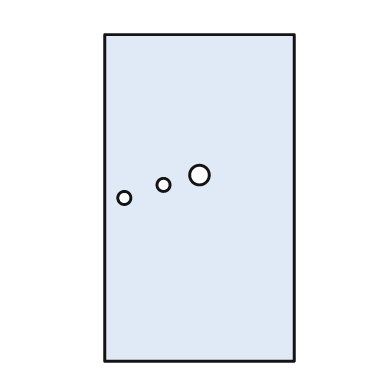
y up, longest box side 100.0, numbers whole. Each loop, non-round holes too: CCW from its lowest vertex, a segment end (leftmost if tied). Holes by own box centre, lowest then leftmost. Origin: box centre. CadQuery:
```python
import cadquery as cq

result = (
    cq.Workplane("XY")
    .moveTo(-29.0, -50.0)
    .lineTo(29.0, -50.0)
    .lineTo(29.0, 50.0)
    .lineTo(-29.0, 50.0)
    .close()
    .moveTo(-23.0, 0.0)
    .circle(2.0)
    .moveTo(-11.0, 4.0)
    .circle(2.0)
    .moveTo(0.0, 7.0)
    .circle(3.0)
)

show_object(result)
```